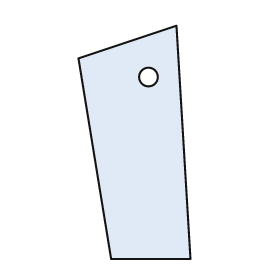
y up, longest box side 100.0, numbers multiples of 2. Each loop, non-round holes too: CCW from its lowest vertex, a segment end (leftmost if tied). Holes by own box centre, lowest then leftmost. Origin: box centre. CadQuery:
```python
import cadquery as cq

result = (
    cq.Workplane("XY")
    .moveTo(-10.0, -50.0)
    .lineTo(24.0, -50.0)
    .lineTo(18.0, 50.0)
    .lineTo(-24.0, 36.0)
    .close()
    .moveTo(6.0, 28.0)
    .circle(4.0)
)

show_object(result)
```